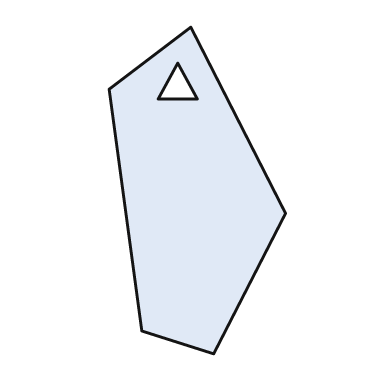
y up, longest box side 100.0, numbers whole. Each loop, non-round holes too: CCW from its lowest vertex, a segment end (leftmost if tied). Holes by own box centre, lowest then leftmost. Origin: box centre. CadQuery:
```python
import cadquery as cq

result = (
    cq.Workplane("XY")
    .moveTo(5.0, -50.0)
    .lineTo(27.0, -7.0)
    .lineTo(-2.0, 50.0)
    .lineTo(-27.0, 31.0)
    .lineTo(-17.0, -43.0)
    .close()
    .moveTo(-12.0, 28.0)
    .lineTo(0.0, 28.0)
    .lineTo(-6.0, 39.0)
    .close()
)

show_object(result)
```